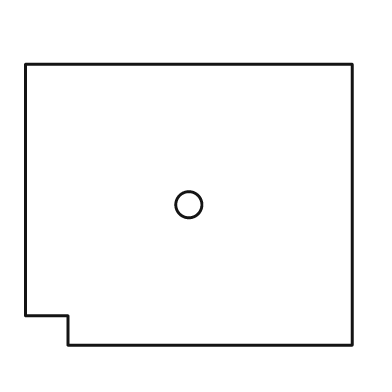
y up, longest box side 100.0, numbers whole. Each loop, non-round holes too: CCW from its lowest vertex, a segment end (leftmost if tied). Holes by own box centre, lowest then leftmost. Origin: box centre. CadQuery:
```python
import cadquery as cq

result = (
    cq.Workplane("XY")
    .moveTo(-37.0, -43.0)
    .lineTo(50.0, -43.0)
    .lineTo(50.0, 43.0)
    .lineTo(-50.0, 43.0)
    .lineTo(-50.0, -34.0)
    .lineTo(-37.0, -34.0)
    .close()
    .moveTo(0.0, 0.0)
    .circle(4.0)
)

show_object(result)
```